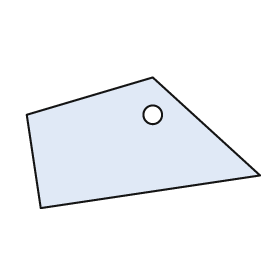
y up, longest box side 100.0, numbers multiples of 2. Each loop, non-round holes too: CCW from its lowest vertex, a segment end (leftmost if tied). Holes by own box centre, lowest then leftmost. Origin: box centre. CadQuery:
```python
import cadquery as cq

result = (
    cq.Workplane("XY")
    .moveTo(-44.0, -28.0)
    .lineTo(50.0, -14.0)
    .lineTo(4.0, 28.0)
    .lineTo(-50.0, 12.0)
    .close()
    .moveTo(4.0, 12.0)
    .circle(4.0)
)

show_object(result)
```